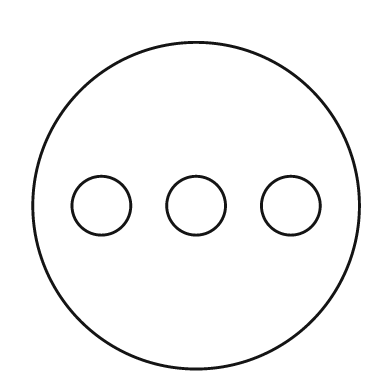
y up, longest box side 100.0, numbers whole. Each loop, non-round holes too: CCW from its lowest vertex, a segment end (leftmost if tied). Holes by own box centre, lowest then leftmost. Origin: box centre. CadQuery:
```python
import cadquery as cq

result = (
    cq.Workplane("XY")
    .moveTo(0.0, 0.0)
    .circle(50.0)
    .moveTo(-29.0, 0.0)
    .circle(9.0)
    .moveTo(0.0, 0.0)
    .circle(9.0)
    .moveTo(29.0, 0.0)
    .circle(9.0)
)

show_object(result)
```